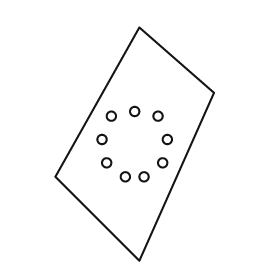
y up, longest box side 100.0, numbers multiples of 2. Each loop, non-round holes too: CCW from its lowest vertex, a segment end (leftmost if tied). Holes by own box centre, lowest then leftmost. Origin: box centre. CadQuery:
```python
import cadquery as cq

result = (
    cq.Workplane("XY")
    .moveTo(2.0, -50.0)
    .lineTo(34.0, 22.0)
    .lineTo(2.0, 50.0)
    .lineTo(-34.0, -14.0)
    .close()
    .moveTo(-4.0, -14.0)
    .circle(2.0)
    .moveTo(4.0, -14.0)
    .circle(2.0)
    .moveTo(-12.0, -8.0)
    .circle(2.0)
    .moveTo(12.0, -8.0)
    .circle(2.0)
    .moveTo(-14.0, 2.0)
    .circle(2.0)
    .moveTo(14.0, 2.0)
    .circle(2.0)
    .moveTo(-10.0, 12.0)
    .circle(2.0)
    .moveTo(10.0, 12.0)
    .circle(2.0)
    .moveTo(0.0, 14.0)
    .circle(2.0)
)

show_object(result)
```